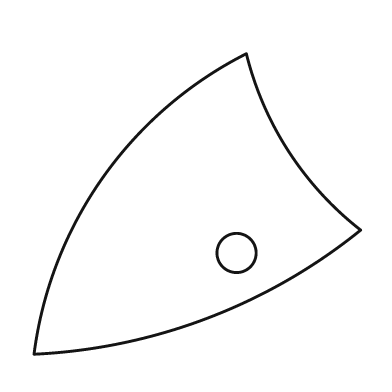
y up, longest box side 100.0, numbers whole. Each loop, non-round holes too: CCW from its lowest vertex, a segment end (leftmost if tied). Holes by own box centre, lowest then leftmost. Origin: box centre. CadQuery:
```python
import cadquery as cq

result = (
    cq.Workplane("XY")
    .moveTo(-50.0, -46.0)
    .threePointArc((3.0, -35.0), (50.0, -8.0))
    .threePointArc((28.0, 16.0), (15.0, 46.0))
    .threePointArc((-29.0, 8.0), (-50.0, -46.0))
    .close()
    .moveTo(12.0, -15.0)
    .circle(6.0)
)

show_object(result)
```